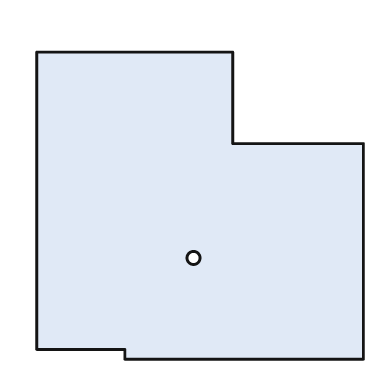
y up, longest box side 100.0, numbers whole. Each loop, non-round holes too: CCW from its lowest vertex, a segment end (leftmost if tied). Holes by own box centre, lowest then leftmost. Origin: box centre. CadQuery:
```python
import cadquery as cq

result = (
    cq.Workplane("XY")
    .moveTo(-23.0, -47.0)
    .lineTo(50.0, -47.0)
    .lineTo(50.0, 19.0)
    .lineTo(10.0, 19.0)
    .lineTo(10.0, 47.0)
    .lineTo(-50.0, 47.0)
    .lineTo(-50.0, -44.0)
    .lineTo(-23.0, -44.0)
    .close()
    .moveTo(-2.0, -16.0)
    .circle(2.0)
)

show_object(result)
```